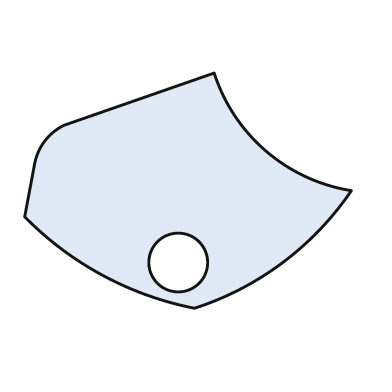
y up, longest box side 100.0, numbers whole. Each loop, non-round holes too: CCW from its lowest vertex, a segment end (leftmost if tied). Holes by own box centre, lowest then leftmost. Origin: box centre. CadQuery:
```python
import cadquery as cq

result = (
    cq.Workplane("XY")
    .moveTo(2.0, -36.0)
    .threePointArc((29.0, -22.0), (50.0, 0.0))
    .threePointArc((24.0, 12.0), (8.0, 36.0))
    .lineTo(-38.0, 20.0)
    .threePointArc((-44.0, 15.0), (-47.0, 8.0))
    .lineTo(-50.0, -8.0)
    .threePointArc((-26.0, -26.0), (2.0, -36.0))
    .close()
    .moveTo(-3.0, -22.0)
    .circle(9.0)
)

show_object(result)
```